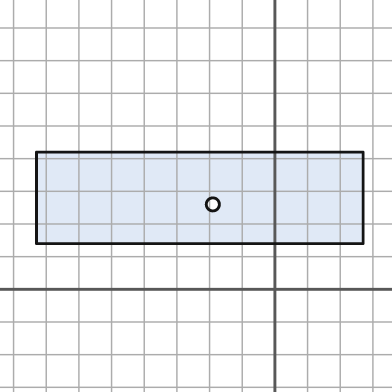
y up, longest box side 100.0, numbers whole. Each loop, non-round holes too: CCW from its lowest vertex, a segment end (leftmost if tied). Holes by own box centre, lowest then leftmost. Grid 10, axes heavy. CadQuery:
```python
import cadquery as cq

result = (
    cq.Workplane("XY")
    .moveTo(-73.0, 14.0)
    .lineTo(27.0, 14.0)
    .lineTo(27.0, 42.0)
    .lineTo(-73.0, 42.0)
    .close()
    .moveTo(-19.0, 26.0)
    .circle(2.0)
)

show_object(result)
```